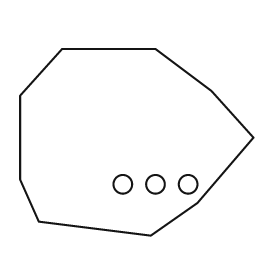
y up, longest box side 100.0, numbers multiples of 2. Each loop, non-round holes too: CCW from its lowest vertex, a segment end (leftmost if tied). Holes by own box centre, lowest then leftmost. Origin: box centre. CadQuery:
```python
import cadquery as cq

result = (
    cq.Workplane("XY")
    .moveTo(6.0, -40.0)
    .lineTo(26.0, -26.0)
    .lineTo(50.0, 2.0)
    .lineTo(32.0, 22.0)
    .lineTo(8.0, 40.0)
    .lineTo(-32.0, 40.0)
    .lineTo(-50.0, 20.0)
    .lineTo(-50.0, -16.0)
    .lineTo(-42.0, -34.0)
    .close()
    .moveTo(-6.0, -18.0)
    .circle(4.0)
    .moveTo(8.0, -18.0)
    .circle(4.0)
    .moveTo(22.0, -18.0)
    .circle(4.0)
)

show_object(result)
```